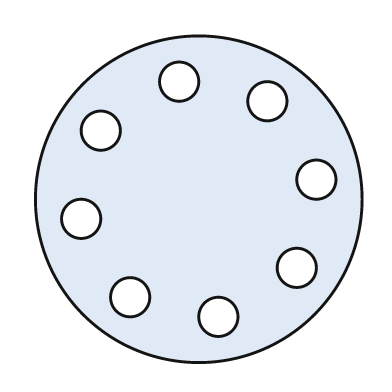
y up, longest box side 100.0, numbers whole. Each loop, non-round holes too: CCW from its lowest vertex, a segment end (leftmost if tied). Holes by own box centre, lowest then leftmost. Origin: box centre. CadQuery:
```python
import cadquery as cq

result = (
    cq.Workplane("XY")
    .moveTo(0.0, 0.0)
    .circle(50.0)
    .moveTo(6.0, -36.0)
    .circle(6.0)
    .moveTo(-21.0, -30.0)
    .circle(6.0)
    .moveTo(30.0, -21.0)
    .circle(6.0)
    .moveTo(-36.0, -6.0)
    .circle(6.0)
    .moveTo(36.0, 6.0)
    .circle(6.0)
    .moveTo(-30.0, 21.0)
    .circle(6.0)
    .moveTo(21.0, 30.0)
    .circle(6.0)
    .moveTo(-6.0, 36.0)
    .circle(6.0)
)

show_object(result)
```